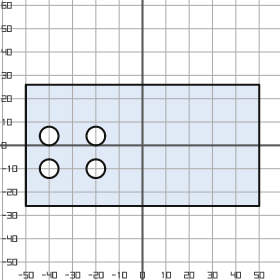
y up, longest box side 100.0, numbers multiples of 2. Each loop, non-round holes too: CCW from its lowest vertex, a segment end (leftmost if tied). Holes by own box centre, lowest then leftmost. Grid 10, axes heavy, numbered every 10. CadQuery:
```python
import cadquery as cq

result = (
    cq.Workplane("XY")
    .moveTo(-50.0, -26.0)
    .lineTo(50.0, -26.0)
    .lineTo(50.0, 26.0)
    .lineTo(-50.0, 26.0)
    .close()
    .moveTo(-40.0, -10.0)
    .circle(4.0)
    .moveTo(-20.0, -10.0)
    .circle(4.0)
    .moveTo(-40.0, 4.0)
    .circle(4.0)
    .moveTo(-20.0, 4.0)
    .circle(4.0)
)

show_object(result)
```